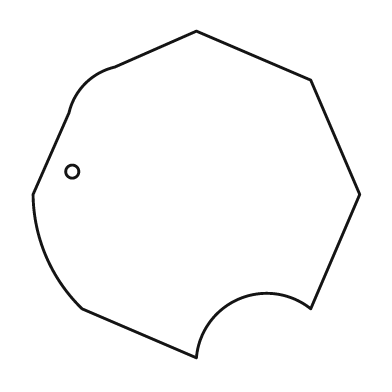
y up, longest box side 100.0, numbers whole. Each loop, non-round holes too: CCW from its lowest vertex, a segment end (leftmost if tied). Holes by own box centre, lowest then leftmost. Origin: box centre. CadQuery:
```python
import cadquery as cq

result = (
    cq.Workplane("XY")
    .moveTo(0.0, -50.0)
    .threePointArc((13.0, -32.0), (35.0, -35.0))
    .lineTo(50.0, 0.0)
    .lineTo(35.0, 35.0)
    .lineTo(0.0, 50.0)
    .lineTo(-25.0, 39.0)
    .threePointArc((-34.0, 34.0), (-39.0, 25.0))
    .lineTo(-50.0, 0.0)
    .threePointArc((-46.0, -19.0), (-35.0, -35.0))
    .close()
    .moveTo(-38.0, 7.0)
    .circle(2.0)
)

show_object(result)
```